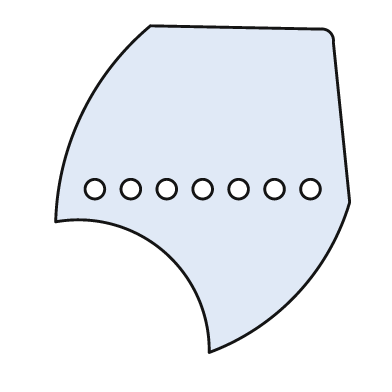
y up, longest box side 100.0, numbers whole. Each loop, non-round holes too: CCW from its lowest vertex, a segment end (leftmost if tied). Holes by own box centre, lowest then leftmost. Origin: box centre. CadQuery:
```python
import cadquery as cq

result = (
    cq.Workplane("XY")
    .moveTo(2.0, -50.0)
    .threePointArc((29.0, -32.0), (45.0, -4.0))
    .lineTo(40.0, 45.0)
    .threePointArc((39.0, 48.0), (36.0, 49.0))
    .lineTo(-16.0, 50.0)
    .threePointArc((-37.0, 23.0), (-45.0, -10.0))
    .threePointArc((-12.0, -19.0), (2.0, -50.0))
    .close()
    .moveTo(-33.0, 0.0)
    .circle(3.0)
    .moveTo(-22.0, 0.0)
    .circle(3.0)
    .moveTo(-11.0, 0.0)
    .circle(3.0)
    .moveTo(0.0, 0.0)
    .circle(3.0)
    .moveTo(11.0, 0.0)
    .circle(3.0)
    .moveTo(22.0, 0.0)
    .circle(3.0)
    .moveTo(33.0, 0.0)
    .circle(3.0)
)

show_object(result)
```